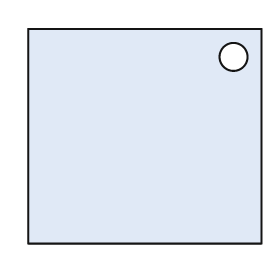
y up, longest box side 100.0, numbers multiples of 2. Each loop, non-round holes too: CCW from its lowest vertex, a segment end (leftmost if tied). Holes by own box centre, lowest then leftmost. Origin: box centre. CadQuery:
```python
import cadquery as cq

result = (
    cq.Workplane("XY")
    .moveTo(-50.0, -46.0)
    .lineTo(50.0, -46.0)
    .lineTo(50.0, 46.0)
    .lineTo(-50.0, 46.0)
    .close()
    .moveTo(38.0, 34.0)
    .circle(6.0)
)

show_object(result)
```